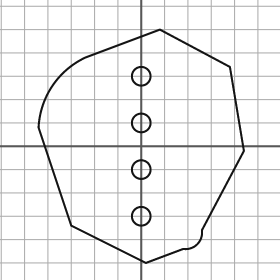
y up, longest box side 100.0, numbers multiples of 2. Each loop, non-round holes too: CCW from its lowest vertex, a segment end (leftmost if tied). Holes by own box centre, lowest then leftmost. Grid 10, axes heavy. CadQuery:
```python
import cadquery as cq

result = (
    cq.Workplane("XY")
    .moveTo(2.0, -50.0)
    .lineTo(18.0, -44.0)
    .threePointArc((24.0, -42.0), (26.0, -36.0))
    .lineTo(44.0, -2.0)
    .lineTo(38.0, 34.0)
    .lineTo(8.0, 50.0)
    .lineTo(-24.0, 38.0)
    .threePointArc((-38.0, 26.0), (-44.0, 8.0))
    .lineTo(-30.0, -34.0)
    .close()
    .moveTo(0.0, -30.0)
    .circle(4.0)
    .moveTo(0.0, -10.0)
    .circle(4.0)
    .moveTo(0.0, 10.0)
    .circle(4.0)
    .moveTo(0.0, 30.0)
    .circle(4.0)
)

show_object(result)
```